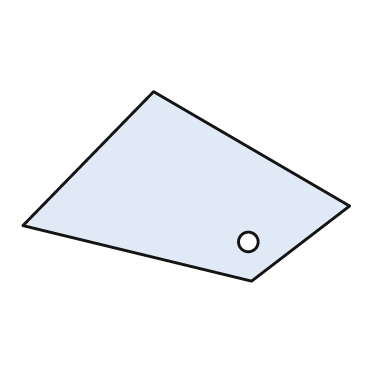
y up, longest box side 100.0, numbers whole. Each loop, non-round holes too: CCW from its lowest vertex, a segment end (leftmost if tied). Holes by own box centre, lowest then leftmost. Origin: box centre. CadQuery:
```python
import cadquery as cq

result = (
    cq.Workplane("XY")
    .moveTo(20.0, -29.0)
    .lineTo(50.0, -6.0)
    .lineTo(-10.0, 29.0)
    .lineTo(-50.0, -12.0)
    .close()
    .moveTo(19.0, -17.0)
    .circle(3.0)
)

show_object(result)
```